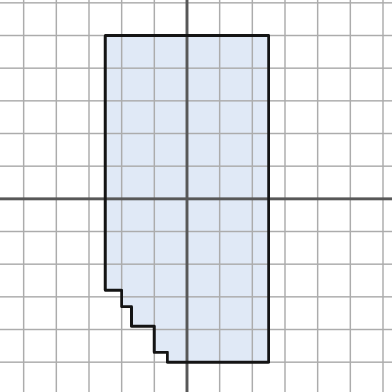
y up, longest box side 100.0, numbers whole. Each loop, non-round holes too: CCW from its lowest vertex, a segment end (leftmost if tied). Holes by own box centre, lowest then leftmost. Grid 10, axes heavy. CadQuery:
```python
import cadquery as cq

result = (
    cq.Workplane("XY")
    .moveTo(-6.0, -50.0)
    .lineTo(25.0, -50.0)
    .lineTo(25.0, 50.0)
    .lineTo(-25.0, 50.0)
    .lineTo(-25.0, -28.0)
    .lineTo(-20.0, -28.0)
    .lineTo(-20.0, -33.0)
    .lineTo(-17.0, -33.0)
    .lineTo(-17.0, -39.0)
    .lineTo(-10.0, -39.0)
    .lineTo(-10.0, -47.0)
    .lineTo(-6.0, -47.0)
    .close()
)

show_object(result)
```